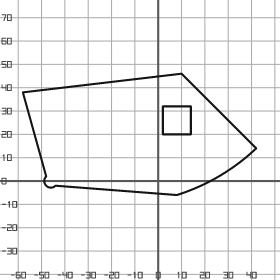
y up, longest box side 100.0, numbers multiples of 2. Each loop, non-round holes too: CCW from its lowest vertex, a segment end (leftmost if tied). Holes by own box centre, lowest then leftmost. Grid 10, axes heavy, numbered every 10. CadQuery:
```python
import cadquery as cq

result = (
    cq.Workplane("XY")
    .moveTo(8.0, -6.0)
    .threePointArc((26.0, 2.0), (42.0, 14.0))
    .lineTo(10.0, 46.0)
    .lineTo(-58.0, 38.0)
    .lineTo(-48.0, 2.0)
    .threePointArc((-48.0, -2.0), (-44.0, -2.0))
    .close()
    .moveTo(2.0, 20.0)
    .lineTo(14.0, 20.0)
    .lineTo(14.0, 32.0)
    .lineTo(2.0, 32.0)
    .close()
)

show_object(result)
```